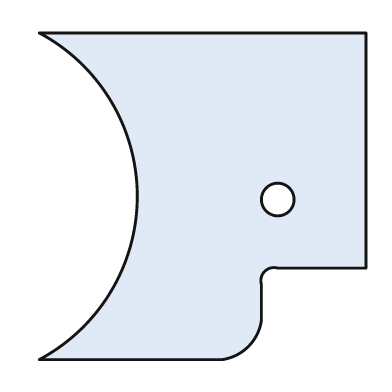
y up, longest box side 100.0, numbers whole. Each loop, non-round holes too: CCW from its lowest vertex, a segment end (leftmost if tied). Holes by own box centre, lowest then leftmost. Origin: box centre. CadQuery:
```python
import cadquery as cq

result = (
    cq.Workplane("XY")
    .moveTo(-50.0, -50.0)
    .lineTo(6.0, -50.0)
    .threePointArc((14.0, -46.0), (18.0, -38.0))
    .lineTo(18.0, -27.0)
    .threePointArc((19.0, -23.0), (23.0, -22.0))
    .lineTo(50.0, -22.0)
    .lineTo(50.0, 50.0)
    .lineTo(-50.0, 50.0)
    .threePointArc((-20.0, 0.0), (-50.0, -50.0))
    .close()
    .moveTo(23.0, -1.0)
    .circle(5.0)
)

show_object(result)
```